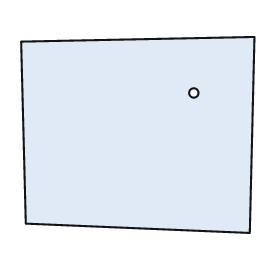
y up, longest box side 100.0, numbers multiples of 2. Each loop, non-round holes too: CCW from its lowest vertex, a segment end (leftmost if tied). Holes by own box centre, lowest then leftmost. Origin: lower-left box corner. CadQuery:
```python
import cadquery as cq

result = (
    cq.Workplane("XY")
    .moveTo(98.0, 0.0)
    .lineTo(100.0, 84.0)
    .lineTo(0.0, 82.0)
    .lineTo(2.0, 4.0)
    .close()
    .moveTo(74.0, 60.0)
    .circle(2.0)
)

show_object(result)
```